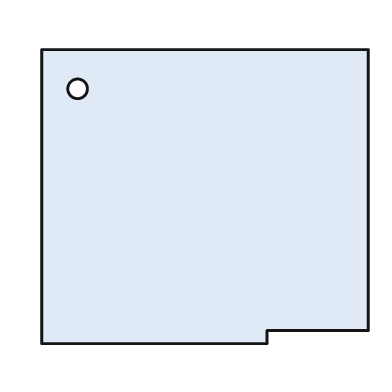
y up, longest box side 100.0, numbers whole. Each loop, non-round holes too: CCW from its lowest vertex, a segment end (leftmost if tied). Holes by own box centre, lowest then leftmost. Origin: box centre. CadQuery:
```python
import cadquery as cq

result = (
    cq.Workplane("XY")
    .moveTo(-50.0, -45.0)
    .lineTo(19.0, -45.0)
    .lineTo(19.0, -41.0)
    .lineTo(50.0, -41.0)
    .lineTo(50.0, 45.0)
    .lineTo(-50.0, 45.0)
    .close()
    .moveTo(-39.0, 33.0)
    .circle(3.0)
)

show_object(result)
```